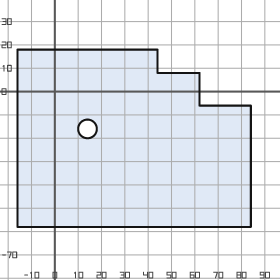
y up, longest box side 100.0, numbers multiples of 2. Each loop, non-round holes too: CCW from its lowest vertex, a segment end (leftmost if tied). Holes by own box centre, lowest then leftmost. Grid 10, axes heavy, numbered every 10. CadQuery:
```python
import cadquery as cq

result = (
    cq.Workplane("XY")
    .moveTo(-16.0, -58.0)
    .lineTo(84.0, -58.0)
    .lineTo(84.0, -6.0)
    .lineTo(62.0, -6.0)
    .lineTo(62.0, 8.0)
    .lineTo(44.0, 8.0)
    .lineTo(44.0, 18.0)
    .lineTo(-16.0, 18.0)
    .close()
    .moveTo(14.0, -16.0)
    .circle(4.0)
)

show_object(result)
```